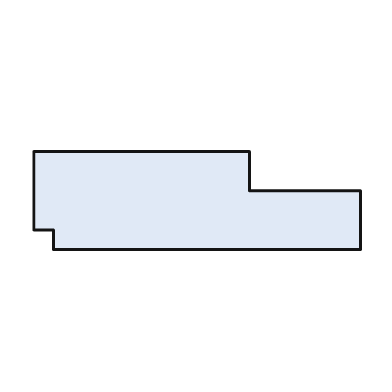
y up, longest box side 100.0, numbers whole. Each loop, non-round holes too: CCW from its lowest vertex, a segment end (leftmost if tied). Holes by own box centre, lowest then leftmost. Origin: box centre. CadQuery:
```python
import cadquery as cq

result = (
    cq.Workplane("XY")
    .moveTo(-44.0, -15.0)
    .lineTo(50.0, -15.0)
    .lineTo(50.0, 3.0)
    .lineTo(16.0, 3.0)
    .lineTo(16.0, 15.0)
    .lineTo(-50.0, 15.0)
    .lineTo(-50.0, -9.0)
    .lineTo(-44.0, -9.0)
    .close()
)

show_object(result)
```